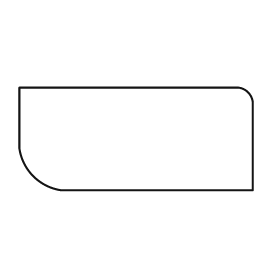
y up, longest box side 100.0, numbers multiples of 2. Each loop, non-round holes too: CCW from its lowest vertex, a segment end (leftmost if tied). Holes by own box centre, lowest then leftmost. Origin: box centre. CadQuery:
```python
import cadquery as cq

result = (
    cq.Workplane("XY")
    .moveTo(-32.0, -22.0)
    .lineTo(50.0, -22.0)
    .lineTo(50.0, 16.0)
    .threePointArc((48.0, 20.0), (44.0, 22.0))
    .lineTo(-50.0, 22.0)
    .lineTo(-50.0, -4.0)
    .threePointArc((-44.0, -16.0), (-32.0, -22.0))
    .close()
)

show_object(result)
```